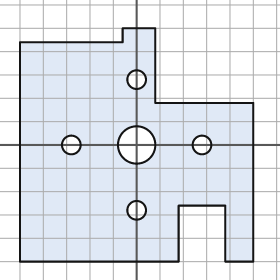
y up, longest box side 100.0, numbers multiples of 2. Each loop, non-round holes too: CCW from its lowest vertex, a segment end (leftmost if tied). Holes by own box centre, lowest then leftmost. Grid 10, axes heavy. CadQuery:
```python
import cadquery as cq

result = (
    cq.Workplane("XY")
    .moveTo(-50.0, -50.0)
    .lineTo(18.0, -50.0)
    .lineTo(18.0, -26.0)
    .lineTo(38.0, -26.0)
    .lineTo(38.0, -50.0)
    .lineTo(50.0, -50.0)
    .lineTo(50.0, 18.0)
    .lineTo(8.0, 18.0)
    .lineTo(8.0, 50.0)
    .lineTo(-6.0, 50.0)
    .lineTo(-6.0, 44.0)
    .lineTo(-50.0, 44.0)
    .close()
    .moveTo(0.0, -28.0)
    .circle(4.0)
    .moveTo(-28.0, 0.0)
    .circle(4.0)
    .moveTo(0.0, 0.0)
    .circle(8.0)
    .moveTo(28.0, 0.0)
    .circle(4.0)
    .moveTo(0.0, 28.0)
    .circle(4.0)
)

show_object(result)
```